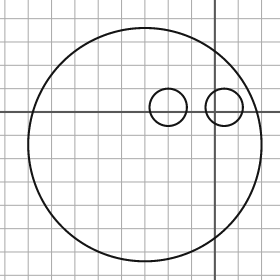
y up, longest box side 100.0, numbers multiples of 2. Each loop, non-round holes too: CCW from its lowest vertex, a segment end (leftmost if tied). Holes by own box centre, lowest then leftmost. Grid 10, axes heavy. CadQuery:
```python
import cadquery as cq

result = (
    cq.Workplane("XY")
    .moveTo(-30.0, -14.0)
    .circle(50.0)
    .moveTo(-20.0, 2.0)
    .circle(8.0)
    .moveTo(4.0, 2.0)
    .circle(8.0)
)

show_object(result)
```